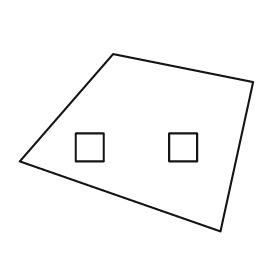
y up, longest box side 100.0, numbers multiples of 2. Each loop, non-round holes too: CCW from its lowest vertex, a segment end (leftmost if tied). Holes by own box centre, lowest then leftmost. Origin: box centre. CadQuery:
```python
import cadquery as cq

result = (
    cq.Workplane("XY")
    .moveTo(36.0, -38.0)
    .lineTo(50.0, 26.0)
    .lineTo(-10.0, 38.0)
    .lineTo(-50.0, -8.0)
    .close()
    .moveTo(-26.0, -8.0)
    .lineTo(-14.0, -8.0)
    .lineTo(-14.0, 4.0)
    .lineTo(-26.0, 4.0)
    .close()
    .moveTo(14.0, -8.0)
    .lineTo(26.0, -8.0)
    .lineTo(26.0, 4.0)
    .lineTo(14.0, 4.0)
    .close()
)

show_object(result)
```